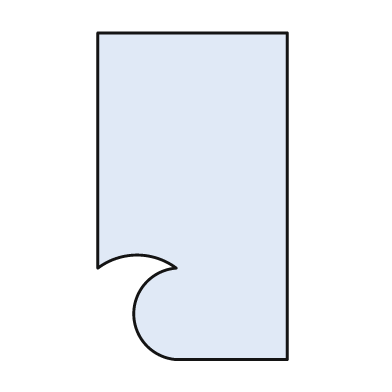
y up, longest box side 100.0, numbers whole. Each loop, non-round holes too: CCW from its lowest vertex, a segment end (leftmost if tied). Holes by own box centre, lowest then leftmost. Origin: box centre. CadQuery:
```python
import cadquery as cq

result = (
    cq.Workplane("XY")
    .moveTo(-5.0, -50.0)
    .lineTo(29.0, -50.0)
    .lineTo(29.0, 50.0)
    .lineTo(-29.0, 50.0)
    .lineTo(-29.0, -22.0)
    .threePointArc((-17.0, -18.0), (-5.0, -22.0))
    .threePointArc((-18.0, -36.0), (-5.0, -50.0))
    .close()
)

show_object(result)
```